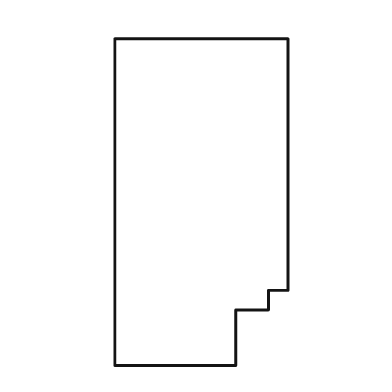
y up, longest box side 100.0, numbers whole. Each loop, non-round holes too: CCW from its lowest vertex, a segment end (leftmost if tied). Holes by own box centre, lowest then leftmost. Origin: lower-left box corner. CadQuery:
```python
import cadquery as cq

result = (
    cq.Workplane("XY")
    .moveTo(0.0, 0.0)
    .lineTo(37.0, 0.0)
    .lineTo(37.0, 17.0)
    .lineTo(47.0, 17.0)
    .lineTo(47.0, 23.0)
    .lineTo(53.0, 23.0)
    .lineTo(53.0, 100.0)
    .lineTo(0.0, 100.0)
    .close()
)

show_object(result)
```